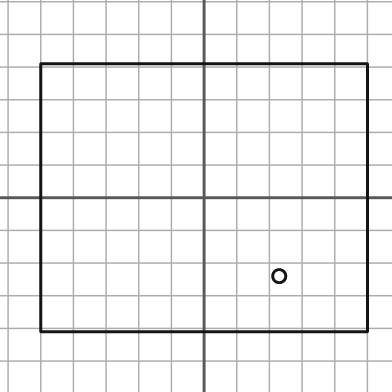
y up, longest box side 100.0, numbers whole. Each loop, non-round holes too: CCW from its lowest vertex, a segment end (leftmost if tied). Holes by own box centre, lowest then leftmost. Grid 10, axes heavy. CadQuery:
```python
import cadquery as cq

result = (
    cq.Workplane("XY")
    .moveTo(-50.0, -41.0)
    .lineTo(50.0, -41.0)
    .lineTo(50.0, 41.0)
    .lineTo(-50.0, 41.0)
    .close()
    .moveTo(23.0, -24.0)
    .circle(2.0)
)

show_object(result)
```